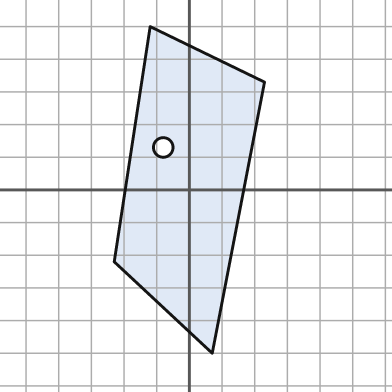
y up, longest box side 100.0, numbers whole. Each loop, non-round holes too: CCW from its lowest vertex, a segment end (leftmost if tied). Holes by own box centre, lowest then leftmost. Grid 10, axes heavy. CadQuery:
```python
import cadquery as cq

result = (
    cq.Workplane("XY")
    .moveTo(7.0, -50.0)
    .lineTo(23.0, 33.0)
    .lineTo(-12.0, 50.0)
    .lineTo(-23.0, -22.0)
    .close()
    .moveTo(-8.0, 13.0)
    .circle(3.0)
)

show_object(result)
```